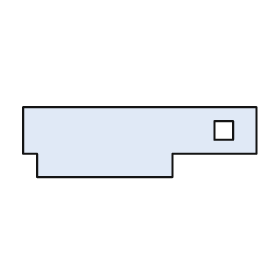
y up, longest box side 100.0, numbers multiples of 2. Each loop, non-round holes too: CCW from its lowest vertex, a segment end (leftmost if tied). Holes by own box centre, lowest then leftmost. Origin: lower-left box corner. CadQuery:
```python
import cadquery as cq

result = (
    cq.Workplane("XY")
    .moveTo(6.0, 0.0)
    .lineTo(64.0, 0.0)
    .lineTo(64.0, 10.0)
    .lineTo(100.0, 10.0)
    .lineTo(100.0, 30.0)
    .lineTo(0.0, 30.0)
    .lineTo(0.0, 10.0)
    .lineTo(6.0, 10.0)
    .close()
    .moveTo(82.0, 16.0)
    .lineTo(90.0, 16.0)
    .lineTo(90.0, 24.0)
    .lineTo(82.0, 24.0)
    .close()
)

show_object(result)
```